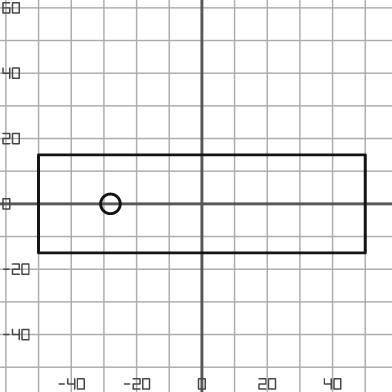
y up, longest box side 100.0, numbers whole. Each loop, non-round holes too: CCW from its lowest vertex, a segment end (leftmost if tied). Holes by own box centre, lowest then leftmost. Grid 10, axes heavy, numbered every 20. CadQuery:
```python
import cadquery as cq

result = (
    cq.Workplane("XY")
    .moveTo(-50.0, -15.0)
    .lineTo(50.0, -15.0)
    .lineTo(50.0, 15.0)
    .lineTo(-50.0, 15.0)
    .close()
    .moveTo(-28.0, 0.0)
    .circle(3.0)
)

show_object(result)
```